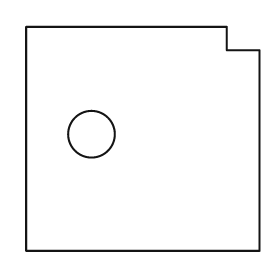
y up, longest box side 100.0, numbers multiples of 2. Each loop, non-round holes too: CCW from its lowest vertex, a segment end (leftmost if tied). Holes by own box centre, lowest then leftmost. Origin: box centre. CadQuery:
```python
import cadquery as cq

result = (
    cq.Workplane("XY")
    .moveTo(-50.0, -48.0)
    .lineTo(50.0, -48.0)
    .lineTo(50.0, 38.0)
    .lineTo(36.0, 38.0)
    .lineTo(36.0, 48.0)
    .lineTo(-50.0, 48.0)
    .close()
    .moveTo(-22.0, 2.0)
    .circle(10.0)
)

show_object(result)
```